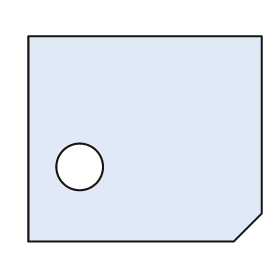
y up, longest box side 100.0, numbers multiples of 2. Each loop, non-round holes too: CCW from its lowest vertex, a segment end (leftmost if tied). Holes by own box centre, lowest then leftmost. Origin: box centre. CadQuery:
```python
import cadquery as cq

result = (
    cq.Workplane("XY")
    .moveTo(-50.0, -44.0)
    .lineTo(38.0, -44.0)
    .lineTo(50.0, -32.0)
    .lineTo(50.0, 44.0)
    .lineTo(-50.0, 44.0)
    .close()
    .moveTo(-28.0, -12.0)
    .circle(10.0)
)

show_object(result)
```